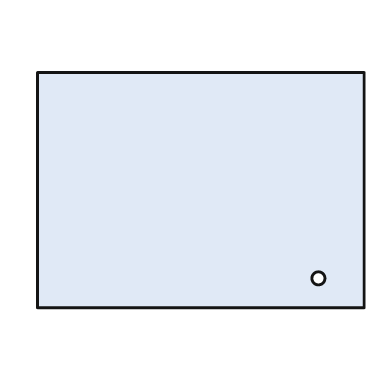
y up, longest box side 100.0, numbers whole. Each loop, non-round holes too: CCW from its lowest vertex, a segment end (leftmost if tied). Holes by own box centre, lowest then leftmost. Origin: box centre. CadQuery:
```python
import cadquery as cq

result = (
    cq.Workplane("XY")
    .moveTo(-50.0, -36.0)
    .lineTo(50.0, -36.0)
    .lineTo(50.0, 36.0)
    .lineTo(-50.0, 36.0)
    .close()
    .moveTo(36.0, -27.0)
    .circle(2.0)
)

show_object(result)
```